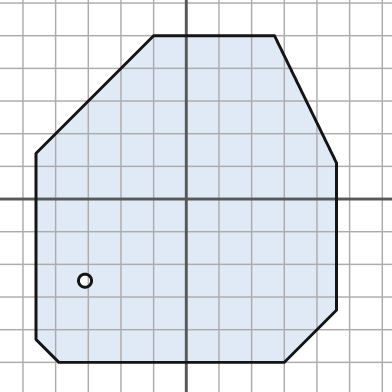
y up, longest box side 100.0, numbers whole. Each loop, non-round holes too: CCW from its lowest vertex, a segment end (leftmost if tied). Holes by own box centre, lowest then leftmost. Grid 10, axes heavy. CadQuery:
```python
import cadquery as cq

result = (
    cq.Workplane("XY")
    .moveTo(-39.0, -50.0)
    .lineTo(30.0, -50.0)
    .lineTo(46.0, -34.0)
    .lineTo(46.0, 11.0)
    .lineTo(27.0, 50.0)
    .lineTo(-10.0, 50.0)
    .lineTo(-46.0, 14.0)
    .lineTo(-46.0, -43.0)
    .close()
    .moveTo(-31.0, -25.0)
    .circle(2.0)
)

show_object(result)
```